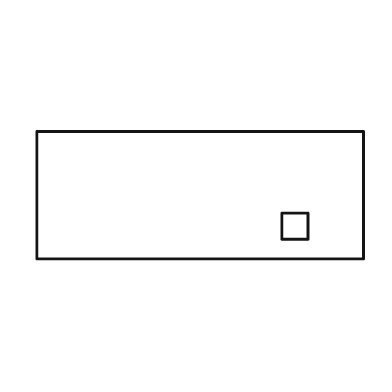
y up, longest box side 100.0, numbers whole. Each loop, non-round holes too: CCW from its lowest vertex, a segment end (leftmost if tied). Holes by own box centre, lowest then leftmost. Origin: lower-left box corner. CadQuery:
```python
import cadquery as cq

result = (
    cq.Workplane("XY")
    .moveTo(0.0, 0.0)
    .lineTo(100.0, 0.0)
    .lineTo(100.0, 39.0)
    .lineTo(0.0, 39.0)
    .close()
    .moveTo(75.0, 6.0)
    .lineTo(83.0, 6.0)
    .lineTo(83.0, 14.0)
    .lineTo(75.0, 14.0)
    .close()
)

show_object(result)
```